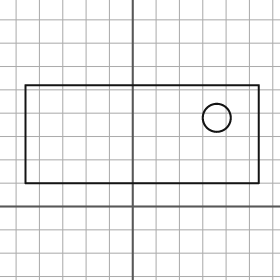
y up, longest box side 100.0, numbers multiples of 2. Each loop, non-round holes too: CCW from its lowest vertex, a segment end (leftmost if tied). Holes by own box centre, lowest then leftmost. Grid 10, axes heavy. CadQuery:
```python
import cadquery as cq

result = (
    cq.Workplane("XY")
    .moveTo(-46.0, 10.0)
    .lineTo(54.0, 10.0)
    .lineTo(54.0, 52.0)
    .lineTo(-46.0, 52.0)
    .close()
    .moveTo(36.0, 38.0)
    .circle(6.0)
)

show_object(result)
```